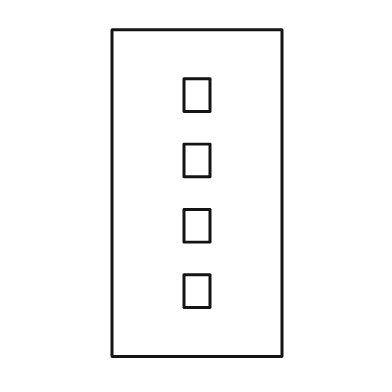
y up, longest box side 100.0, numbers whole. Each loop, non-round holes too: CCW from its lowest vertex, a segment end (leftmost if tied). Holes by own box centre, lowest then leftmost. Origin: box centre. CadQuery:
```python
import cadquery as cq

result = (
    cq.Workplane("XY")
    .moveTo(-26.0, -50.0)
    .lineTo(26.0, -50.0)
    .lineTo(26.0, 50.0)
    .lineTo(-26.0, 50.0)
    .close()
    .moveTo(-4.0, -35.0)
    .lineTo(4.0, -35.0)
    .lineTo(4.0, -25.0)
    .lineTo(-4.0, -25.0)
    .close()
    .moveTo(-4.0, -15.0)
    .lineTo(4.0, -15.0)
    .lineTo(4.0, -5.0)
    .lineTo(-4.0, -5.0)
    .close()
    .moveTo(-4.0, 5.0)
    .lineTo(4.0, 5.0)
    .lineTo(4.0, 15.0)
    .lineTo(-4.0, 15.0)
    .close()
    .moveTo(-4.0, 25.0)
    .lineTo(4.0, 25.0)
    .lineTo(4.0, 35.0)
    .lineTo(-4.0, 35.0)
    .close()
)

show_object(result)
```